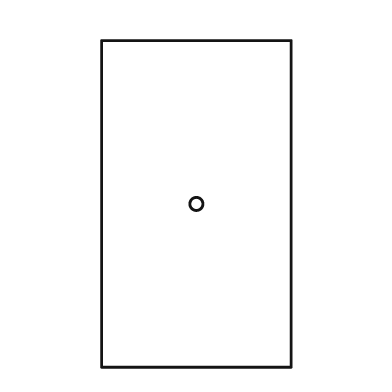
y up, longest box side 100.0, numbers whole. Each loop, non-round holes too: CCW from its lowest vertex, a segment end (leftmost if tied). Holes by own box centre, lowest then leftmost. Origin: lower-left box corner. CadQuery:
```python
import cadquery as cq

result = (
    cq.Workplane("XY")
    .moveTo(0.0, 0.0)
    .lineTo(58.0, 0.0)
    .lineTo(58.0, 100.0)
    .lineTo(0.0, 100.0)
    .close()
    .moveTo(29.0, 50.0)
    .circle(2.0)
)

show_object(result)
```